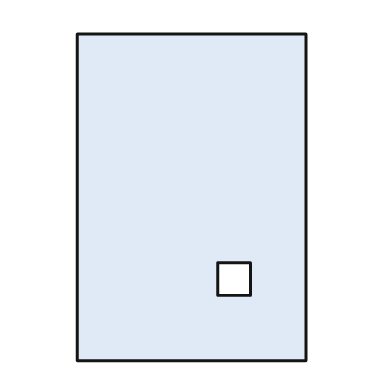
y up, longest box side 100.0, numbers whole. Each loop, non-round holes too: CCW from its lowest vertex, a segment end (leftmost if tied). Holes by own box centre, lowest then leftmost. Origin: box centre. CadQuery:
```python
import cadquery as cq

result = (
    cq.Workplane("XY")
    .moveTo(-35.0, -50.0)
    .lineTo(35.0, -50.0)
    .lineTo(35.0, 50.0)
    .lineTo(-35.0, 50.0)
    .close()
    .moveTo(8.0, -30.0)
    .lineTo(18.0, -30.0)
    .lineTo(18.0, -20.0)
    .lineTo(8.0, -20.0)
    .close()
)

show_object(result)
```